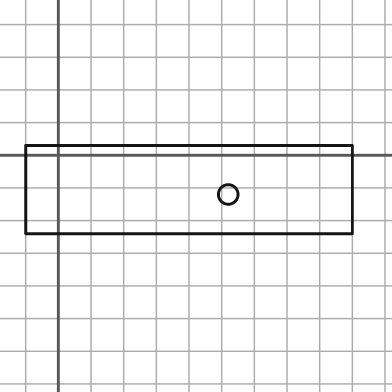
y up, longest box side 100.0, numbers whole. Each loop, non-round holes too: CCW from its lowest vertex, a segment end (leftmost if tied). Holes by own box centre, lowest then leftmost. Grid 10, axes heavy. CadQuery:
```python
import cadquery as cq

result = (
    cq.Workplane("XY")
    .moveTo(-10.0, -24.0)
    .lineTo(90.0, -24.0)
    .lineTo(90.0, 3.0)
    .lineTo(-10.0, 3.0)
    .close()
    .moveTo(52.0, -12.0)
    .circle(3.0)
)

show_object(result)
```